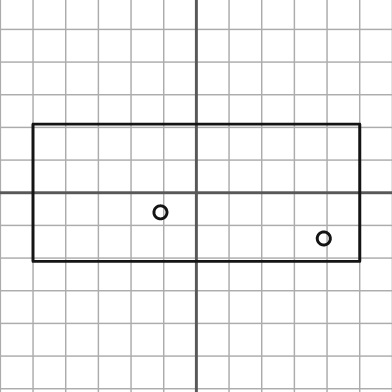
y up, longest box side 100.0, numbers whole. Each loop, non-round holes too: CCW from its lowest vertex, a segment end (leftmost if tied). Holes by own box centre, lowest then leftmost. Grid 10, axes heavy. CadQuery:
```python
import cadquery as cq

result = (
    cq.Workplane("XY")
    .moveTo(-50.0, -21.0)
    .lineTo(50.0, -21.0)
    .lineTo(50.0, 21.0)
    .lineTo(-50.0, 21.0)
    .close()
    .moveTo(39.0, -14.0)
    .circle(2.0)
    .moveTo(-11.0, -6.0)
    .circle(2.0)
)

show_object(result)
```